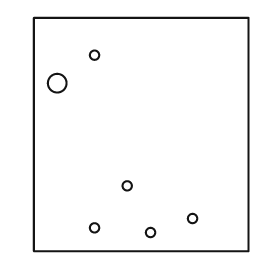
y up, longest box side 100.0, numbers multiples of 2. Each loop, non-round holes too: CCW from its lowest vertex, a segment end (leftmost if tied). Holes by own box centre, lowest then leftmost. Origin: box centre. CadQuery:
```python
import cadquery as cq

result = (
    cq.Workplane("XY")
    .moveTo(-46.0, -50.0)
    .lineTo(46.0, -50.0)
    .lineTo(46.0, 50.0)
    .lineTo(-46.0, 50.0)
    .close()
    .moveTo(4.0, -42.0)
    .circle(2.0)
    .moveTo(-20.0, -40.0)
    .circle(2.0)
    .moveTo(22.0, -36.0)
    .circle(2.0)
    .moveTo(-6.0, -22.0)
    .circle(2.0)
    .moveTo(-36.0, 22.0)
    .circle(4.0)
    .moveTo(-20.0, 34.0)
    .circle(2.0)
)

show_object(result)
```